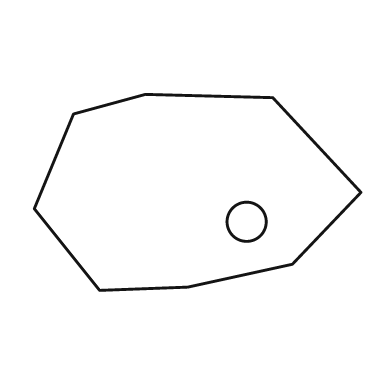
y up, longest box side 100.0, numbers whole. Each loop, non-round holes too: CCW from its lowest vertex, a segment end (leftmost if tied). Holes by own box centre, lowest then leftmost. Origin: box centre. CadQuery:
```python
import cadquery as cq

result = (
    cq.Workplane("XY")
    .moveTo(-30.0, -30.0)
    .lineTo(-3.0, -29.0)
    .lineTo(29.0, -22.0)
    .lineTo(50.0, 0.0)
    .lineTo(23.0, 29.0)
    .lineTo(-16.0, 30.0)
    .lineTo(-38.0, 24.0)
    .lineTo(-50.0, -5.0)
    .close()
    .moveTo(15.0, -9.0)
    .circle(6.0)
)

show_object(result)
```